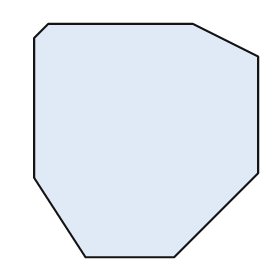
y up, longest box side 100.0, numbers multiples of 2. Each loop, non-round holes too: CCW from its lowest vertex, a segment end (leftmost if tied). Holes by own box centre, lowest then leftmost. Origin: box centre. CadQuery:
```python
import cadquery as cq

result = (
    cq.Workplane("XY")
    .moveTo(-26.0, -50.0)
    .lineTo(12.0, -50.0)
    .lineTo(48.0, -14.0)
    .lineTo(48.0, 36.0)
    .lineTo(20.0, 50.0)
    .lineTo(-42.0, 50.0)
    .lineTo(-48.0, 44.0)
    .lineTo(-48.0, -16.0)
    .close()
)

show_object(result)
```